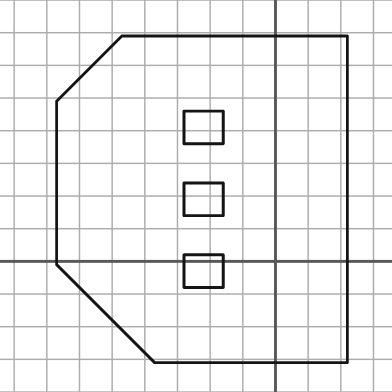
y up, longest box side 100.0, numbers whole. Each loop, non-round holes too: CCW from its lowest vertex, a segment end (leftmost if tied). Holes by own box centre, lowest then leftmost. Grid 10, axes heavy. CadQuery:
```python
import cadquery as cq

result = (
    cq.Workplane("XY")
    .moveTo(-37.0, -31.0)
    .lineTo(22.0, -31.0)
    .lineTo(22.0, 69.0)
    .lineTo(-47.0, 69.0)
    .lineTo(-67.0, 49.0)
    .lineTo(-67.0, -1.0)
    .close()
    .moveTo(-28.0, -8.0)
    .lineTo(-16.0, -8.0)
    .lineTo(-16.0, 2.0)
    .lineTo(-28.0, 2.0)
    .close()
    .moveTo(-28.0, 14.0)
    .lineTo(-16.0, 14.0)
    .lineTo(-16.0, 24.0)
    .lineTo(-28.0, 24.0)
    .close()
    .moveTo(-28.0, 36.0)
    .lineTo(-16.0, 36.0)
    .lineTo(-16.0, 46.0)
    .lineTo(-28.0, 46.0)
    .close()
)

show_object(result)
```